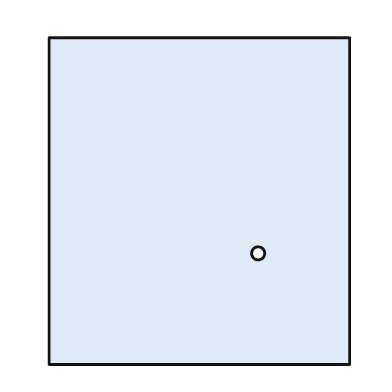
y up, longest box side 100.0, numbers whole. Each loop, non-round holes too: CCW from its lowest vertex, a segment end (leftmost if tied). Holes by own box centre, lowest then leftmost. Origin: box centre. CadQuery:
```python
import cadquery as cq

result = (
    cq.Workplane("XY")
    .moveTo(-46.0, -50.0)
    .lineTo(46.0, -50.0)
    .lineTo(46.0, 50.0)
    .lineTo(-46.0, 50.0)
    .close()
    .moveTo(18.0, -16.0)
    .circle(2.0)
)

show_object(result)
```